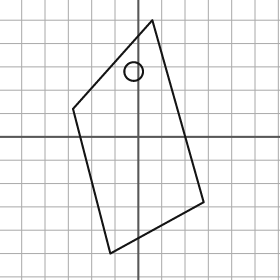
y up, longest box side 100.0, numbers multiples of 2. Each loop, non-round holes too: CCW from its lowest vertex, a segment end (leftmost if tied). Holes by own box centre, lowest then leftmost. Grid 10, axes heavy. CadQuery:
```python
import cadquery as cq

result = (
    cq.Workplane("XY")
    .moveTo(-12.0, -50.0)
    .lineTo(28.0, -28.0)
    .lineTo(6.0, 50.0)
    .lineTo(-28.0, 12.0)
    .close()
    .moveTo(-2.0, 28.0)
    .circle(4.0)
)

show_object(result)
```